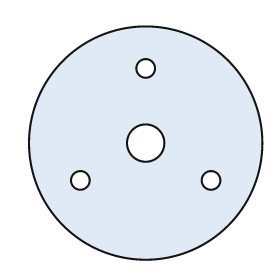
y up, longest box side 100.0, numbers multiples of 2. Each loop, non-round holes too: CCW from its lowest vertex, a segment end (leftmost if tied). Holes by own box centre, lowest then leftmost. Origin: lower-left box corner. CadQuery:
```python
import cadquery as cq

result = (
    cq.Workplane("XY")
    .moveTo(50.0, 50.0)
    .circle(50.0)
    .moveTo(22.0, 34.0)
    .circle(4.0)
    .moveTo(78.0, 34.0)
    .circle(4.0)
    .moveTo(50.0, 50.0)
    .circle(8.0)
    .moveTo(50.0, 82.0)
    .circle(4.0)
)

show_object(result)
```